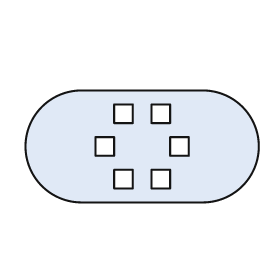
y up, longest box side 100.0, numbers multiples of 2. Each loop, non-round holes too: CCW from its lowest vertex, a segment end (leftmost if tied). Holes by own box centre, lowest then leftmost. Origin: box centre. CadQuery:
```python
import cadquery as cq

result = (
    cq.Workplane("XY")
    .moveTo(-26.0, -24.0)
    .lineTo(26.0, -24.0)
    .threePointArc((50.0, 0.0), (26.0, 24.0))
    .lineTo(-26.0, 24.0)
    .threePointArc((-50.0, 0.0), (-26.0, -24.0))
    .close()
    .moveTo(-12.0, -18.0)
    .lineTo(-4.0, -18.0)
    .lineTo(-4.0, -10.0)
    .lineTo(-12.0, -10.0)
    .close()
    .moveTo(4.0, -18.0)
    .lineTo(12.0, -18.0)
    .lineTo(12.0, -10.0)
    .lineTo(4.0, -10.0)
    .close()
    .moveTo(-20.0, -4.0)
    .lineTo(-12.0, -4.0)
    .lineTo(-12.0, 4.0)
    .lineTo(-20.0, 4.0)
    .close()
    .moveTo(12.0, -4.0)
    .lineTo(20.0, -4.0)
    .lineTo(20.0, 4.0)
    .lineTo(12.0, 4.0)
    .close()
    .moveTo(-12.0, 10.0)
    .lineTo(-4.0, 10.0)
    .lineTo(-4.0, 18.0)
    .lineTo(-12.0, 18.0)
    .close()
    .moveTo(4.0, 10.0)
    .lineTo(12.0, 10.0)
    .lineTo(12.0, 18.0)
    .lineTo(4.0, 18.0)
    .close()
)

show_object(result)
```